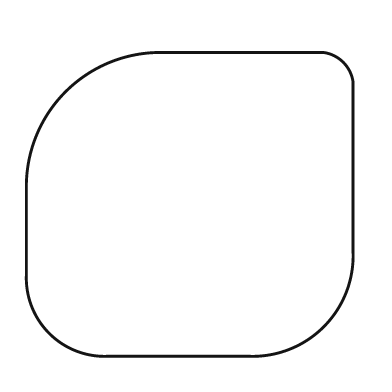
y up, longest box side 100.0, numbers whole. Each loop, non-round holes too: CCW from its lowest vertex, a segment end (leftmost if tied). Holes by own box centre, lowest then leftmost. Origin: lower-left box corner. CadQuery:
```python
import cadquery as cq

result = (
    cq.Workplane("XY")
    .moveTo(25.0, 0.0)
    .lineTo(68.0, 0.0)
    .threePointArc((91.0, 9.0), (100.0, 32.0))
    .lineTo(100.0, 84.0)
    .threePointArc((97.0, 90.0), (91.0, 93.0))
    .lineTo(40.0, 93.0)
    .threePointArc((12.0, 81.0), (0.0, 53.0))
    .lineTo(0.0, 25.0)
    .threePointArc((7.0, 7.0), (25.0, 0.0))
    .close()
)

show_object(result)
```